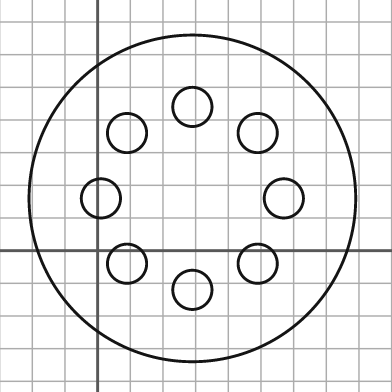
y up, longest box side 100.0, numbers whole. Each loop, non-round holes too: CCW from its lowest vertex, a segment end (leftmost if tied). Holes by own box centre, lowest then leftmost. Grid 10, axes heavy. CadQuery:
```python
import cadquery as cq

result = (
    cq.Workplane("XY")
    .moveTo(29.0, 16.0)
    .circle(50.0)
    .moveTo(29.0, -12.0)
    .circle(6.0)
    .moveTo(9.0, -4.0)
    .circle(6.0)
    .moveTo(49.0, -4.0)
    .circle(6.0)
    .moveTo(1.0, 16.0)
    .circle(6.0)
    .moveTo(57.0, 16.0)
    .circle(6.0)
    .moveTo(9.0, 36.0)
    .circle(6.0)
    .moveTo(49.0, 36.0)
    .circle(6.0)
    .moveTo(29.0, 44.0)
    .circle(6.0)
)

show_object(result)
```